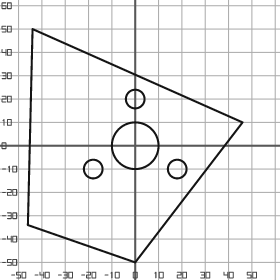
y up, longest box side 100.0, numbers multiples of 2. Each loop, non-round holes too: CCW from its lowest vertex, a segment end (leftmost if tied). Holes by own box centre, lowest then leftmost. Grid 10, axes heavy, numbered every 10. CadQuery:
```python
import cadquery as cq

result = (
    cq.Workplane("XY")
    .moveTo(0.0, -50.0)
    .lineTo(46.0, 10.0)
    .lineTo(-44.0, 50.0)
    .lineTo(-46.0, -34.0)
    .close()
    .moveTo(-18.0, -10.0)
    .circle(4.0)
    .moveTo(18.0, -10.0)
    .circle(4.0)
    .moveTo(0.0, 0.0)
    .circle(10.0)
    .moveTo(0.0, 20.0)
    .circle(4.0)
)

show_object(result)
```